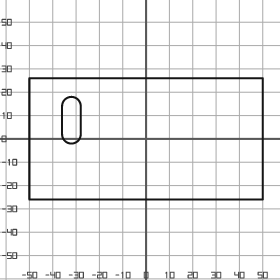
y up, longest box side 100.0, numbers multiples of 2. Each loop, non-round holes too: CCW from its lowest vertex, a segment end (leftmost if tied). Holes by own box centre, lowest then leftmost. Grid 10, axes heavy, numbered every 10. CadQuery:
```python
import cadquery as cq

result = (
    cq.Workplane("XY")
    .moveTo(-50.0, -26.0)
    .lineTo(50.0, -26.0)
    .lineTo(50.0, 26.0)
    .lineTo(-50.0, 26.0)
    .close()
    .moveTo(-36.0, 2.0)
    .threePointArc((-32.0, -2.0), (-28.0, 2.0))
    .lineTo(-28.0, 14.0)
    .threePointArc((-32.0, 18.0), (-36.0, 14.0))
    .close()
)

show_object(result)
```